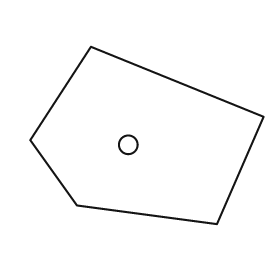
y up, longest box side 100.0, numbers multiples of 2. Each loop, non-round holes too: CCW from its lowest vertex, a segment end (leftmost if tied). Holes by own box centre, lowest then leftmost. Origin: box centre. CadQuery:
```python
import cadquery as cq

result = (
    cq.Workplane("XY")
    .moveTo(30.0, -38.0)
    .lineTo(50.0, 8.0)
    .lineTo(-24.0, 38.0)
    .lineTo(-50.0, -2.0)
    .lineTo(-30.0, -30.0)
    .close()
    .moveTo(-8.0, -4.0)
    .circle(4.0)
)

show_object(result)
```